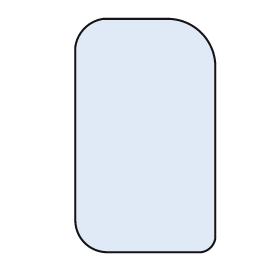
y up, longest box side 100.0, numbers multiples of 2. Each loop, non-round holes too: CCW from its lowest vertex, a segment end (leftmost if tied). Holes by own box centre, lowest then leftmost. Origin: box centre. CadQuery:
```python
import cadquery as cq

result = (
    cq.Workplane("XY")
    .moveTo(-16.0, -50.0)
    .lineTo(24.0, -50.0)
    .threePointArc((28.0, -48.0), (30.0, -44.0))
    .lineTo(30.0, 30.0)
    .threePointArc((24.0, 44.0), (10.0, 50.0))
    .lineTo(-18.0, 50.0)
    .threePointArc((-26.0, 46.0), (-30.0, 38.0))
    .lineTo(-30.0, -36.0)
    .threePointArc((-26.0, -46.0), (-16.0, -50.0))
    .close()
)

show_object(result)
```